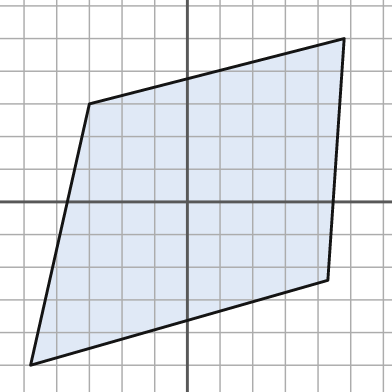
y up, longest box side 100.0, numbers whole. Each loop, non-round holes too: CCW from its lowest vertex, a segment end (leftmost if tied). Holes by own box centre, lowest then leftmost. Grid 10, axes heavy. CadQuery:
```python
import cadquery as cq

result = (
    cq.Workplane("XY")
    .moveTo(-48.0, -50.0)
    .lineTo(43.0, -24.0)
    .lineTo(48.0, 50.0)
    .lineTo(-30.0, 30.0)
    .close()
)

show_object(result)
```